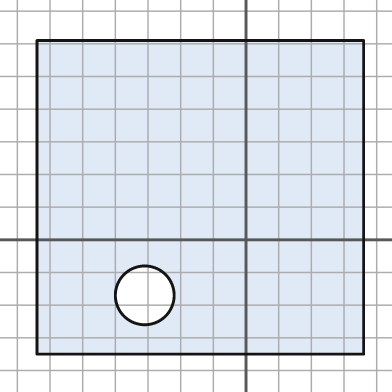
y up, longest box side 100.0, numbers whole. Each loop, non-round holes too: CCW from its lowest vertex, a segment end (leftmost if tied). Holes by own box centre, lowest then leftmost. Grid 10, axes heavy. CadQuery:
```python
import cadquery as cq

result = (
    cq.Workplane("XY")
    .moveTo(-64.0, -35.0)
    .lineTo(36.0, -35.0)
    .lineTo(36.0, 61.0)
    .lineTo(-64.0, 61.0)
    .close()
    .moveTo(-31.0, -17.0)
    .circle(9.0)
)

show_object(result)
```